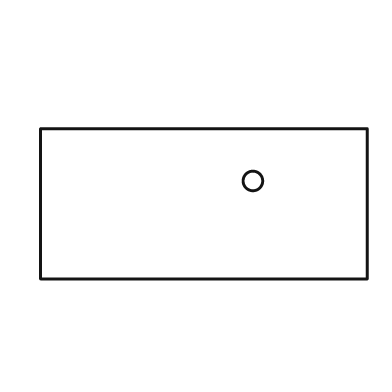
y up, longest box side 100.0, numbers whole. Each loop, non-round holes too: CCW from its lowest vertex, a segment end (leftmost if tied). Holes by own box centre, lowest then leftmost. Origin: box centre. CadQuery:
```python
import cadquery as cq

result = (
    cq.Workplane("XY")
    .moveTo(-50.0, -23.0)
    .lineTo(50.0, -23.0)
    .lineTo(50.0, 23.0)
    .lineTo(-50.0, 23.0)
    .close()
    .moveTo(15.0, 7.0)
    .circle(3.0)
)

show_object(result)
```